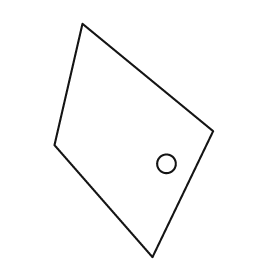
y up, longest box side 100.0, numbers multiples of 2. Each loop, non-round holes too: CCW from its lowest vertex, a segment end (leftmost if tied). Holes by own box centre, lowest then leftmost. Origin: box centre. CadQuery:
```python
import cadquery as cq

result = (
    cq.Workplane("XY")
    .moveTo(8.0, -50.0)
    .lineTo(34.0, 4.0)
    .lineTo(-22.0, 50.0)
    .lineTo(-34.0, -2.0)
    .close()
    .moveTo(14.0, -10.0)
    .circle(4.0)
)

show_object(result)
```